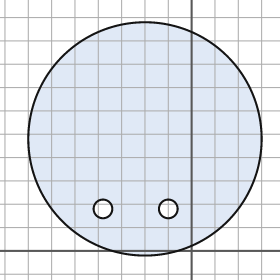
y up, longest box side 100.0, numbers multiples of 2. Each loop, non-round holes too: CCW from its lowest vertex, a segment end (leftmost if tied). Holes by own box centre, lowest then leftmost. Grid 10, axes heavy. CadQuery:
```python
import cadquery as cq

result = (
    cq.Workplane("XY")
    .moveTo(-20.0, 48.0)
    .circle(50.0)
    .moveTo(-38.0, 18.0)
    .circle(4.0)
    .moveTo(-10.0, 18.0)
    .circle(4.0)
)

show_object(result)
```